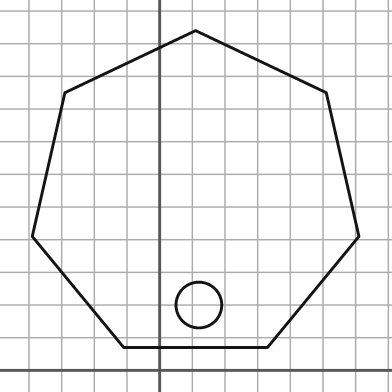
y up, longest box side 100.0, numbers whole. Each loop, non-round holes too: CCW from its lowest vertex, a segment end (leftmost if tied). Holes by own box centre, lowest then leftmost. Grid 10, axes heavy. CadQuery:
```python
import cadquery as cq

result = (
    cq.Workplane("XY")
    .moveTo(-11.0, 7.0)
    .lineTo(33.0, 7.0)
    .lineTo(61.0, 41.0)
    .lineTo(51.0, 85.0)
    .lineTo(11.0, 104.0)
    .lineTo(-29.0, 85.0)
    .lineTo(-39.0, 41.0)
    .close()
    .moveTo(12.0, 20.0)
    .circle(7.0)
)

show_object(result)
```